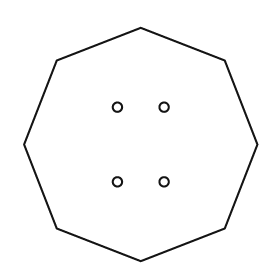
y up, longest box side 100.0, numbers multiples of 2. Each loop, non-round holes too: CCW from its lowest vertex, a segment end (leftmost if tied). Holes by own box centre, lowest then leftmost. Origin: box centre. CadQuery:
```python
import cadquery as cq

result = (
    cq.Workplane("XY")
    .moveTo(0.0, -50.0)
    .lineTo(36.0, -36.0)
    .lineTo(50.0, 0.0)
    .lineTo(36.0, 36.0)
    .lineTo(0.0, 50.0)
    .lineTo(-36.0, 36.0)
    .lineTo(-50.0, 0.0)
    .lineTo(-36.0, -36.0)
    .close()
    .moveTo(-10.0, -16.0)
    .circle(2.0)
    .moveTo(10.0, -16.0)
    .circle(2.0)
    .moveTo(-10.0, 16.0)
    .circle(2.0)
    .moveTo(10.0, 16.0)
    .circle(2.0)
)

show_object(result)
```